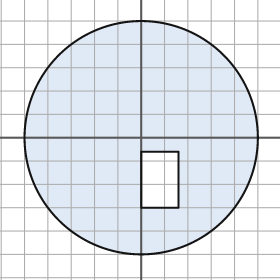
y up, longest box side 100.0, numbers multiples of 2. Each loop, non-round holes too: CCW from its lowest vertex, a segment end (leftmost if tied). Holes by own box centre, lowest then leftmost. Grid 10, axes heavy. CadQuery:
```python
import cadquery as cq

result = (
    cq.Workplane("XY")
    .moveTo(0.0, 0.0)
    .circle(50.0)
    .moveTo(0.0, -30.0)
    .lineTo(16.0, -30.0)
    .lineTo(16.0, -6.0)
    .lineTo(0.0, -6.0)
    .close()
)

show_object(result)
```